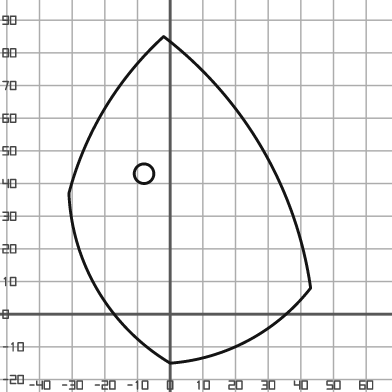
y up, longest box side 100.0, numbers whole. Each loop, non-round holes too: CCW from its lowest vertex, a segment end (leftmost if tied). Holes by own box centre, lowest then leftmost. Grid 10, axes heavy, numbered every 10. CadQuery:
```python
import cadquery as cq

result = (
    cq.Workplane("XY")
    .moveTo(0.0, -15.0)
    .threePointArc((24.0, -8.0), (43.0, 8.0))
    .threePointArc((28.0, 51.0), (-2.0, 85.0))
    .threePointArc((-20.0, 63.0), (-31.0, 37.0))
    .threePointArc((-22.0, 7.0), (0.0, -15.0))
    .close()
    .moveTo(-8.0, 43.0)
    .circle(3.0)
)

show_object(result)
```